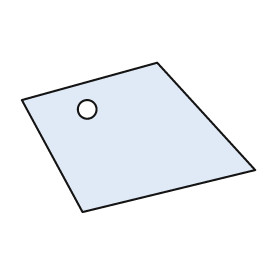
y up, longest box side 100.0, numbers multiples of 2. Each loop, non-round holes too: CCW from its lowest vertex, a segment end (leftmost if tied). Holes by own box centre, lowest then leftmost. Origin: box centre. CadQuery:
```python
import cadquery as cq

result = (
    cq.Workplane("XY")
    .moveTo(-24.0, -32.0)
    .lineTo(50.0, -14.0)
    .lineTo(8.0, 32.0)
    .lineTo(-50.0, 16.0)
    .close()
    .moveTo(-22.0, 12.0)
    .circle(4.0)
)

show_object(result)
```